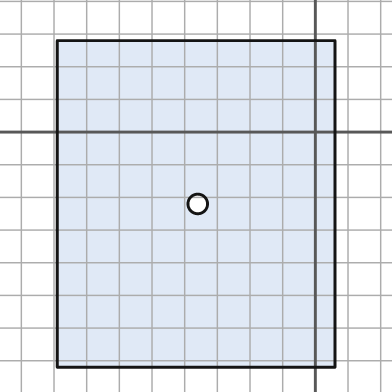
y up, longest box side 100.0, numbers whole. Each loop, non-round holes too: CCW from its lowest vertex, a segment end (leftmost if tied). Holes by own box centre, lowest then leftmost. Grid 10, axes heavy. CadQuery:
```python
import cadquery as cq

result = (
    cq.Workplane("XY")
    .moveTo(-79.0, -72.0)
    .lineTo(6.0, -72.0)
    .lineTo(6.0, 28.0)
    .lineTo(-79.0, 28.0)
    .close()
    .moveTo(-36.0, -22.0)
    .circle(3.0)
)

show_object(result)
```